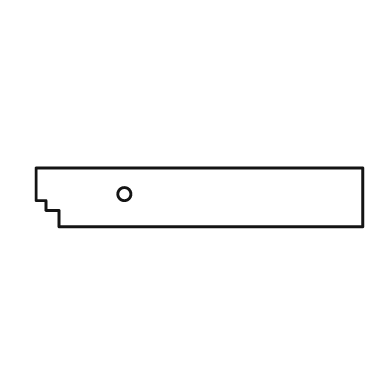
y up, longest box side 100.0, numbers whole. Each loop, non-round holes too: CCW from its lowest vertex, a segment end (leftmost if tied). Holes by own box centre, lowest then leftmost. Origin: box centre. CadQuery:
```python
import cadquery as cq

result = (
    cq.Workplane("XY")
    .moveTo(-43.0, -9.0)
    .lineTo(50.0, -9.0)
    .lineTo(50.0, 9.0)
    .lineTo(-50.0, 9.0)
    .lineTo(-50.0, -1.0)
    .lineTo(-47.0, -1.0)
    .lineTo(-47.0, -4.0)
    .lineTo(-43.0, -4.0)
    .close()
    .moveTo(-23.0, 1.0)
    .circle(2.0)
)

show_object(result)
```